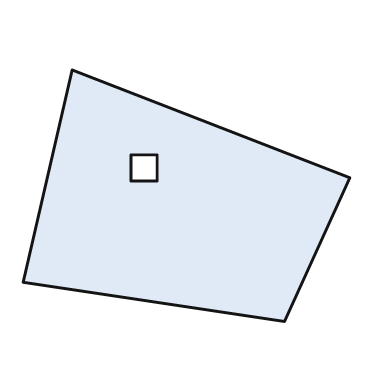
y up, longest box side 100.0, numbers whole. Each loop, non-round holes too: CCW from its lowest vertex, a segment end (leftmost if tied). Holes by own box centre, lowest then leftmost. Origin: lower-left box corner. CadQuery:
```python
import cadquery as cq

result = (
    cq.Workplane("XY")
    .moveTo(80.0, 0.0)
    .lineTo(100.0, 44.0)
    .lineTo(15.0, 77.0)
    .lineTo(0.0, 12.0)
    .close()
    .moveTo(33.0, 43.0)
    .lineTo(41.0, 43.0)
    .lineTo(41.0, 51.0)
    .lineTo(33.0, 51.0)
    .close()
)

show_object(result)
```